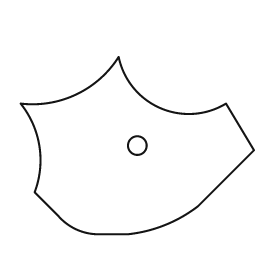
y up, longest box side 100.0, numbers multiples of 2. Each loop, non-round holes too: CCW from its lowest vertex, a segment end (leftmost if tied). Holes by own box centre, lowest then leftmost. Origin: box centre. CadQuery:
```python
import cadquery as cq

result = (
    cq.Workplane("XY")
    .moveTo(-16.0, -38.0)
    .lineTo(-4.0, -38.0)
    .threePointArc((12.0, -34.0), (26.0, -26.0))
    .lineTo(50.0, -2.0)
    .lineTo(38.0, 18.0)
    .threePointArc((10.0, 16.0), (-8.0, 38.0))
    .threePointArc((-26.0, 22.0), (-50.0, 18.0))
    .threePointArc((-42.0, 0.0), (-44.0, -20.0))
    .lineTo(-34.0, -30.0)
    .threePointArc((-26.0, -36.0), (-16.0, -38.0))
    .close()
    .moveTo(0.0, 0.0)
    .circle(4.0)
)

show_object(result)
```